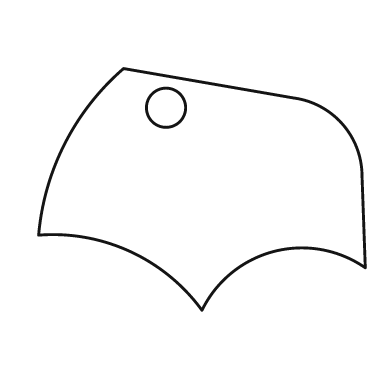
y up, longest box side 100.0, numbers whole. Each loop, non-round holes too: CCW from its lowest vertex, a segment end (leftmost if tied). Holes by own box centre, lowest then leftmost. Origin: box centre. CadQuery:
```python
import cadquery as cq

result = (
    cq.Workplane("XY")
    .moveTo(0.0, -37.0)
    .threePointArc((22.0, -19.0), (50.0, -24.0))
    .lineTo(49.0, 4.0)
    .threePointArc((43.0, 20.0), (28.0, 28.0))
    .lineTo(-24.0, 37.0)
    .threePointArc((-42.0, 14.0), (-50.0, -14.0))
    .threePointArc((-22.0, -19.0), (0.0, -37.0))
    .close()
    .moveTo(-11.0, 25.0)
    .circle(6.0)
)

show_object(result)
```